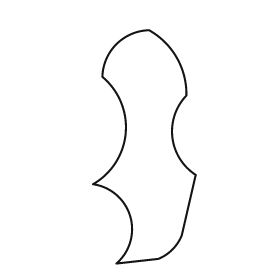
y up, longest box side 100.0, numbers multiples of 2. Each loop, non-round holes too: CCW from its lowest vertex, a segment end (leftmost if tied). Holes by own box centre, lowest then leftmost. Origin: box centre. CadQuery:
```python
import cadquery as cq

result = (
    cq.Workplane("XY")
    .moveTo(-12.0, -50.0)
    .lineTo(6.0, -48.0)
    .threePointArc((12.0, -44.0), (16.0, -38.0))
    .lineTo(22.0, -12.0)
    .threePointArc((12.0, 4.0), (18.0, 22.0))
    .threePointArc((14.0, 38.0), (2.0, 50.0))
    .threePointArc((-12.0, 44.0), (-18.0, 30.0))
    .threePointArc((-8.0, 6.0), (-22.0, -16.0))
    .threePointArc((-6.0, -30.0), (-12.0, -50.0))
    .close()
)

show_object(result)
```